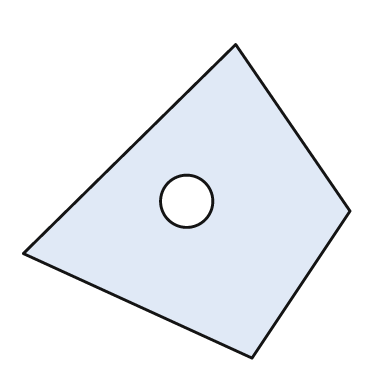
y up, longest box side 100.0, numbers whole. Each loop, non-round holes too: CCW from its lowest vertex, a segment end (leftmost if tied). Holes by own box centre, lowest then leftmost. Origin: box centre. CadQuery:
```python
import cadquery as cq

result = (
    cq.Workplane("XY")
    .moveTo(20.0, -48.0)
    .lineTo(50.0, -3.0)
    .lineTo(15.0, 48.0)
    .lineTo(-50.0, -16.0)
    .close()
    .moveTo(0.0, 0.0)
    .circle(8.0)
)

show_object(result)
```